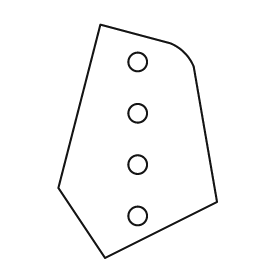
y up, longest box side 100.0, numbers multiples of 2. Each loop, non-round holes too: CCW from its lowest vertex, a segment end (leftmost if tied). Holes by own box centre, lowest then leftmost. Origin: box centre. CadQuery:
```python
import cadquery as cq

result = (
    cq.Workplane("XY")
    .moveTo(-14.0, -50.0)
    .lineTo(34.0, -26.0)
    .lineTo(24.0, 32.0)
    .threePointArc((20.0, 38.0), (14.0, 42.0))
    .lineTo(-16.0, 50.0)
    .lineTo(-34.0, -20.0)
    .close()
    .moveTo(0.0, -32.0)
    .circle(4.0)
    .moveTo(0.0, -10.0)
    .circle(4.0)
    .moveTo(0.0, 12.0)
    .circle(4.0)
    .moveTo(0.0, 34.0)
    .circle(4.0)
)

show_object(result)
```